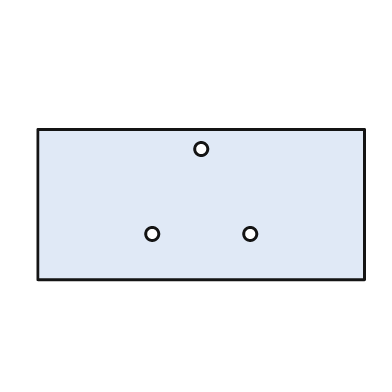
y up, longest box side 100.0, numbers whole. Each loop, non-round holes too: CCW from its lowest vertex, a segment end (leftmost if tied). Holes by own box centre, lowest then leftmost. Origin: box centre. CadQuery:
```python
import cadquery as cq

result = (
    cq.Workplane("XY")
    .moveTo(-50.0, -23.0)
    .lineTo(50.0, -23.0)
    .lineTo(50.0, 23.0)
    .lineTo(-50.0, 23.0)
    .close()
    .moveTo(-15.0, -9.0)
    .circle(2.0)
    .moveTo(15.0, -9.0)
    .circle(2.0)
    .moveTo(0.0, 17.0)
    .circle(2.0)
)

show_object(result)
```